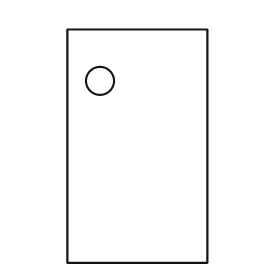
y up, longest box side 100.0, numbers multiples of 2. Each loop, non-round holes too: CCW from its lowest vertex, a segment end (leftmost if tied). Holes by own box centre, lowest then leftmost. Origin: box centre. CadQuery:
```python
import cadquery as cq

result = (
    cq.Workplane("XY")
    .moveTo(-30.0, -50.0)
    .lineTo(30.0, -50.0)
    .lineTo(30.0, 50.0)
    .lineTo(-30.0, 50.0)
    .close()
    .moveTo(-16.0, 28.0)
    .circle(6.0)
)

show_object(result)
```